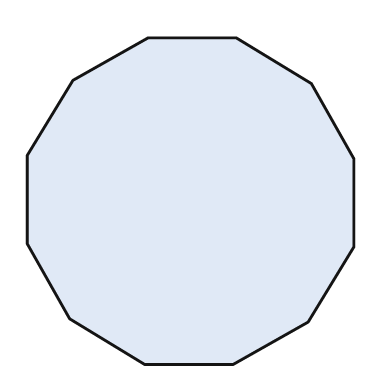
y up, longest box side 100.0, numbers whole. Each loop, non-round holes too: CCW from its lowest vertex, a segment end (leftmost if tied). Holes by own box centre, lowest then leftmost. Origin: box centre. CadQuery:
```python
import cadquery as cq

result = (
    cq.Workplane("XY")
    .moveTo(-14.0, -50.0)
    .lineTo(13.0, -50.0)
    .lineTo(36.0, -37.0)
    .lineTo(50.0, -14.0)
    .lineTo(50.0, 13.0)
    .lineTo(37.0, 36.0)
    .lineTo(14.0, 50.0)
    .lineTo(-13.0, 50.0)
    .lineTo(-36.0, 37.0)
    .lineTo(-50.0, 14.0)
    .lineTo(-50.0, -13.0)
    .lineTo(-37.0, -36.0)
    .close()
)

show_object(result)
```